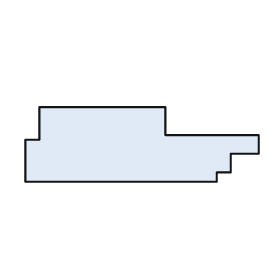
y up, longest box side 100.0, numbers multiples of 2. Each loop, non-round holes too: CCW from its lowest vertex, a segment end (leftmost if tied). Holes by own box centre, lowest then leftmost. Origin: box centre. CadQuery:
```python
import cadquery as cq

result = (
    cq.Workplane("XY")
    .moveTo(-50.0, -16.0)
    .lineTo(32.0, -16.0)
    .lineTo(32.0, -12.0)
    .lineTo(38.0, -12.0)
    .lineTo(38.0, -4.0)
    .lineTo(50.0, -4.0)
    .lineTo(50.0, 4.0)
    .lineTo(10.0, 4.0)
    .lineTo(10.0, 16.0)
    .lineTo(-44.0, 16.0)
    .lineTo(-44.0, 2.0)
    .lineTo(-50.0, 2.0)
    .close()
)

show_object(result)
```